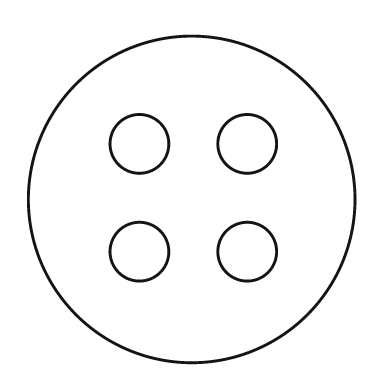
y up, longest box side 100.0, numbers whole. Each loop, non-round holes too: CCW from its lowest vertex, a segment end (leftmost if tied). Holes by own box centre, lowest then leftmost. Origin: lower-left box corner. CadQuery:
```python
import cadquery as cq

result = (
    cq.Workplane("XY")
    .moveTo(50.0, 50.0)
    .circle(50.0)
    .moveTo(34.0, 34.0)
    .circle(9.0)
    .moveTo(67.0, 34.0)
    .circle(9.0)
    .moveTo(34.0, 67.0)
    .circle(9.0)
    .moveTo(67.0, 67.0)
    .circle(9.0)
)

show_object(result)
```